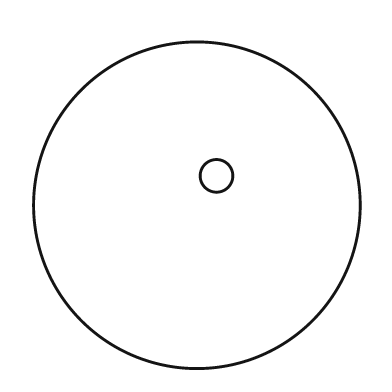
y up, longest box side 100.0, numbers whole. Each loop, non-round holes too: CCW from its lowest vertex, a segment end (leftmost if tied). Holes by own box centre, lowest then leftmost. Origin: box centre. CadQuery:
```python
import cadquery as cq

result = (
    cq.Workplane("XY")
    .moveTo(0.0, 0.0)
    .circle(50.0)
    .moveTo(6.0, 9.0)
    .circle(5.0)
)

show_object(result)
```